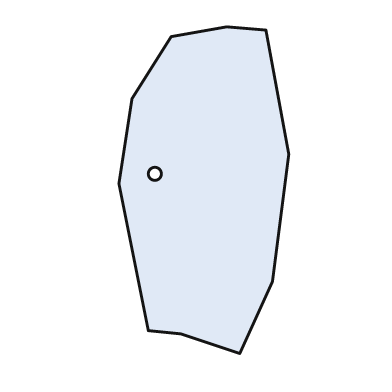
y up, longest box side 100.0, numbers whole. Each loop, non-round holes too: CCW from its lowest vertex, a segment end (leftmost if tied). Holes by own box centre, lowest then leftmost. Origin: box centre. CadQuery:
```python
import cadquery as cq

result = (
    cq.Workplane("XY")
    .moveTo(11.0, -50.0)
    .lineTo(21.0, -28.0)
    .lineTo(26.0, 11.0)
    .lineTo(19.0, 49.0)
    .lineTo(7.0, 50.0)
    .lineTo(-10.0, 47.0)
    .lineTo(-22.0, 28.0)
    .lineTo(-26.0, 2.0)
    .lineTo(-17.0, -43.0)
    .lineTo(-7.0, -44.0)
    .close()
    .moveTo(-15.0, 5.0)
    .circle(2.0)
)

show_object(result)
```